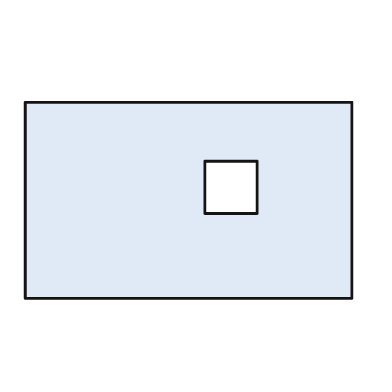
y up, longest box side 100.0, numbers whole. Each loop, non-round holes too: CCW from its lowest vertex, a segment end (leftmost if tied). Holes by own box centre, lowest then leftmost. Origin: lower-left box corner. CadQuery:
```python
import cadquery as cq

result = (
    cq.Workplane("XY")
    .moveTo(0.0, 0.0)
    .lineTo(100.0, 0.0)
    .lineTo(100.0, 60.0)
    .lineTo(0.0, 60.0)
    .close()
    .moveTo(55.0, 26.0)
    .lineTo(71.0, 26.0)
    .lineTo(71.0, 42.0)
    .lineTo(55.0, 42.0)
    .close()
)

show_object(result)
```